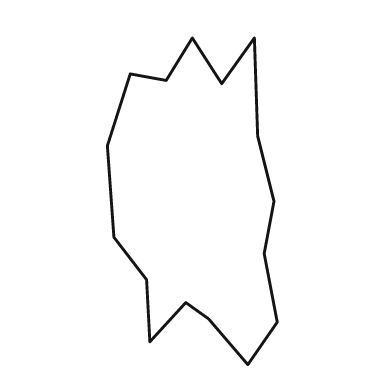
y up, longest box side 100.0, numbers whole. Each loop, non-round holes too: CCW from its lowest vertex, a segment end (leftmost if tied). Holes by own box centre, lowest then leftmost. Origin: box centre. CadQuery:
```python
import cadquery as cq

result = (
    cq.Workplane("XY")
    .moveTo(17.0, -50.0)
    .lineTo(26.0, -37.0)
    .lineTo(22.0, -16.0)
    .lineTo(25.0, 0.0)
    .lineTo(20.0, 20.0)
    .lineTo(19.0, 50.0)
    .lineTo(9.0, 36.0)
    .lineTo(0.0, 50.0)
    .lineTo(-8.0, 37.0)
    .lineTo(-19.0, 39.0)
    .lineTo(-26.0, 17.0)
    .lineTo(-24.0, -11.0)
    .lineTo(-14.0, -24.0)
    .lineTo(-13.0, -43.0)
    .lineTo(-2.0, -31.0)
    .lineTo(5.0, -36.0)
    .close()
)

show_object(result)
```